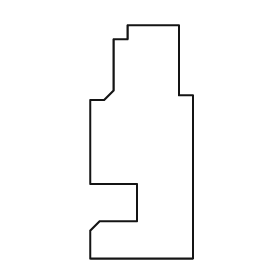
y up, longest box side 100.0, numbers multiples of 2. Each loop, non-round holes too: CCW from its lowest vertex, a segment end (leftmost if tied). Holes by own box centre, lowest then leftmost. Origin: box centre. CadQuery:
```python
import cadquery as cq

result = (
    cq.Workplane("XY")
    .moveTo(-22.0, -50.0)
    .lineTo(22.0, -50.0)
    .lineTo(22.0, 20.0)
    .lineTo(16.0, 20.0)
    .lineTo(16.0, 50.0)
    .lineTo(-6.0, 50.0)
    .lineTo(-6.0, 44.0)
    .lineTo(-12.0, 44.0)
    .lineTo(-12.0, 22.0)
    .lineTo(-16.0, 18.0)
    .lineTo(-22.0, 18.0)
    .lineTo(-22.0, -18.0)
    .lineTo(-2.0, -18.0)
    .lineTo(-2.0, -34.0)
    .lineTo(-18.0, -34.0)
    .lineTo(-22.0, -38.0)
    .close()
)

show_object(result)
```